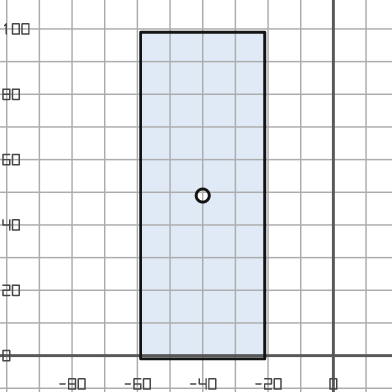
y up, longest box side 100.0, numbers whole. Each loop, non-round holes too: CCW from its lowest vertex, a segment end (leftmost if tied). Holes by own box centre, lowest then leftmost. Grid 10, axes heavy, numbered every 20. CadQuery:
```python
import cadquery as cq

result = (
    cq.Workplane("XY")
    .moveTo(-59.0, -1.0)
    .lineTo(-21.0, -1.0)
    .lineTo(-21.0, 99.0)
    .lineTo(-59.0, 99.0)
    .close()
    .moveTo(-40.0, 49.0)
    .circle(2.0)
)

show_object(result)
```